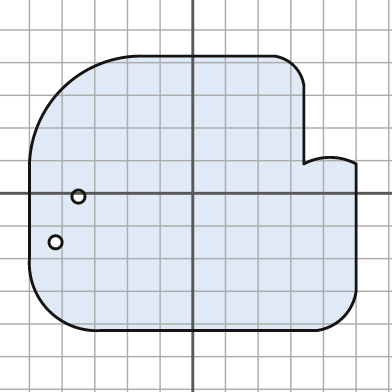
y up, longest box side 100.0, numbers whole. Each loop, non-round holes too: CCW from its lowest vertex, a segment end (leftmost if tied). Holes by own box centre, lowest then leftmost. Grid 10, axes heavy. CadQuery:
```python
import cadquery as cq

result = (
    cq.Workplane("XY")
    .moveTo(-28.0, -42.0)
    .lineTo(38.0, -42.0)
    .threePointArc((46.0, -38.0), (50.0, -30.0))
    .lineTo(50.0, 9.0)
    .threePointArc((42.0, 11.0), (34.0, 9.0))
    .lineTo(34.0, 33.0)
    .threePointArc((31.0, 39.0), (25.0, 42.0))
    .lineTo(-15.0, 42.0)
    .threePointArc((-40.0, 32.0), (-50.0, 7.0))
    .lineTo(-50.0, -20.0)
    .threePointArc((-44.0, -36.0), (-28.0, -42.0))
    .close()
    .moveTo(-42.0, -15.0)
    .circle(2.0)
    .moveTo(-35.0, -1.0)
    .circle(2.0)
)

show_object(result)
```